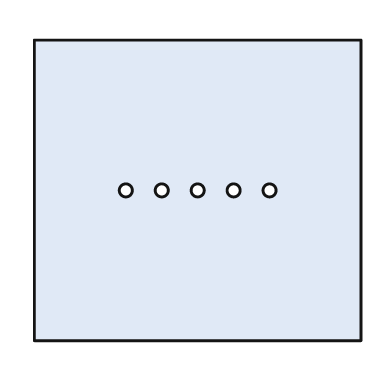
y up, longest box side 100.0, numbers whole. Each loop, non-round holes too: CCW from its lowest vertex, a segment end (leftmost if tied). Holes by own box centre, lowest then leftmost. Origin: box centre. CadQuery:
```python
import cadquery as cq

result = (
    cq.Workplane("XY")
    .moveTo(-50.0, -46.0)
    .lineTo(50.0, -46.0)
    .lineTo(50.0, 46.0)
    .lineTo(-50.0, 46.0)
    .close()
    .moveTo(-22.0, 0.0)
    .circle(2.0)
    .moveTo(-11.0, 0.0)
    .circle(2.0)
    .moveTo(0.0, 0.0)
    .circle(2.0)
    .moveTo(11.0, 0.0)
    .circle(2.0)
    .moveTo(22.0, 0.0)
    .circle(2.0)
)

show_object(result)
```